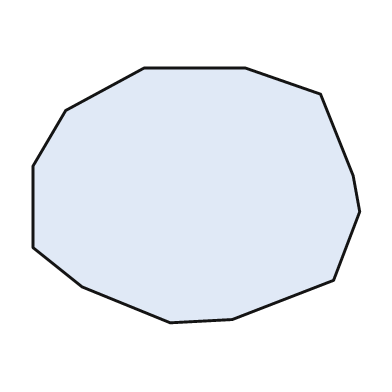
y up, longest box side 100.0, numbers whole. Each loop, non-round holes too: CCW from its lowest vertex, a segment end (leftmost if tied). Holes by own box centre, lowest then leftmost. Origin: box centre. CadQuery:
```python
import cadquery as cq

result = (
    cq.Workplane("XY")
    .moveTo(-8.0, -39.0)
    .lineTo(11.0, -38.0)
    .lineTo(42.0, -26.0)
    .lineTo(50.0, -5.0)
    .lineTo(48.0, 6.0)
    .lineTo(38.0, 31.0)
    .lineTo(15.0, 39.0)
    .lineTo(-16.0, 39.0)
    .lineTo(-40.0, 26.0)
    .lineTo(-50.0, 9.0)
    .lineTo(-50.0, -16.0)
    .lineTo(-35.0, -28.0)
    .close()
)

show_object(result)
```